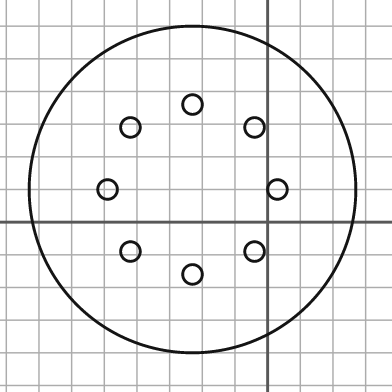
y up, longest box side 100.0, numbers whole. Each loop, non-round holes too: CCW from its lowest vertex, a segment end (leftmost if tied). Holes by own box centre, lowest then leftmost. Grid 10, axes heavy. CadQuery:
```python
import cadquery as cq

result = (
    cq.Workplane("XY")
    .moveTo(-23.0, 10.0)
    .circle(50.0)
    .moveTo(-23.0, -16.0)
    .circle(3.0)
    .moveTo(-42.0, -9.0)
    .circle(3.0)
    .moveTo(-4.0, -9.0)
    .circle(3.0)
    .moveTo(-49.0, 10.0)
    .circle(3.0)
    .moveTo(3.0, 10.0)
    .circle(3.0)
    .moveTo(-42.0, 29.0)
    .circle(3.0)
    .moveTo(-4.0, 29.0)
    .circle(3.0)
    .moveTo(-23.0, 36.0)
    .circle(3.0)
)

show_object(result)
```